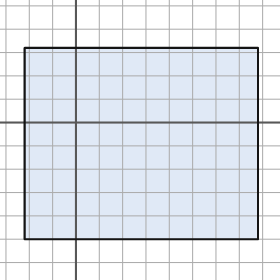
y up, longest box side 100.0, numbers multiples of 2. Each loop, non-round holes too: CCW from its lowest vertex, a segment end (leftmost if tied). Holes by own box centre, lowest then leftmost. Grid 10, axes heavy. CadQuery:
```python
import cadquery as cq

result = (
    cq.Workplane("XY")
    .moveTo(-22.0, -50.0)
    .lineTo(78.0, -50.0)
    .lineTo(78.0, 32.0)
    .lineTo(-22.0, 32.0)
    .close()
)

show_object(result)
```